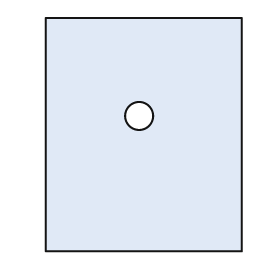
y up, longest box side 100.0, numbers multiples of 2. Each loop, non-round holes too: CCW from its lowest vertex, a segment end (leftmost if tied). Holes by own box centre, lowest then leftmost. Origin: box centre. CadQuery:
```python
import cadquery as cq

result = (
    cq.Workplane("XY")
    .moveTo(-42.0, -50.0)
    .lineTo(42.0, -50.0)
    .lineTo(42.0, 50.0)
    .lineTo(-42.0, 50.0)
    .close()
    .moveTo(-2.0, 8.0)
    .circle(6.0)
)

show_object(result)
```